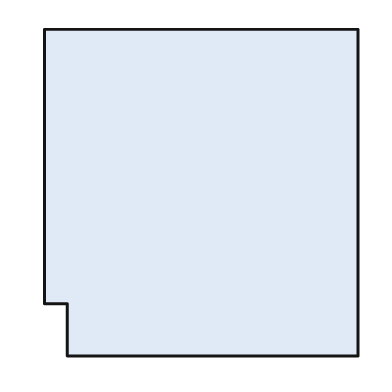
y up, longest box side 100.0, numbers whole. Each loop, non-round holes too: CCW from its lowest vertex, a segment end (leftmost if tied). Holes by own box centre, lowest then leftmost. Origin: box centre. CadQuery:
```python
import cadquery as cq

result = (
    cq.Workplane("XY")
    .moveTo(-41.0, -50.0)
    .lineTo(48.0, -50.0)
    .lineTo(48.0, 50.0)
    .lineTo(-48.0, 50.0)
    .lineTo(-48.0, -34.0)
    .lineTo(-41.0, -34.0)
    .close()
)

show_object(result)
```